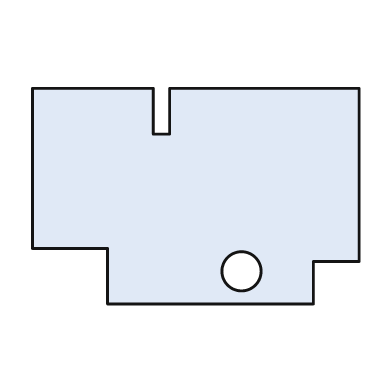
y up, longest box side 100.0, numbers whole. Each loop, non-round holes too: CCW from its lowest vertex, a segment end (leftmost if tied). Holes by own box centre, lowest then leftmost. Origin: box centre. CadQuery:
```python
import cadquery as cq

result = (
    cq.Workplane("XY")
    .moveTo(-27.0, -33.0)
    .lineTo(36.0, -33.0)
    .lineTo(36.0, -20.0)
    .lineTo(50.0, -20.0)
    .lineTo(50.0, 33.0)
    .lineTo(-8.0, 33.0)
    .lineTo(-8.0, 19.0)
    .lineTo(-13.0, 19.0)
    .lineTo(-13.0, 33.0)
    .lineTo(-50.0, 33.0)
    .lineTo(-50.0, -16.0)
    .lineTo(-27.0, -16.0)
    .close()
    .moveTo(14.0, -23.0)
    .circle(6.0)
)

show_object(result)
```